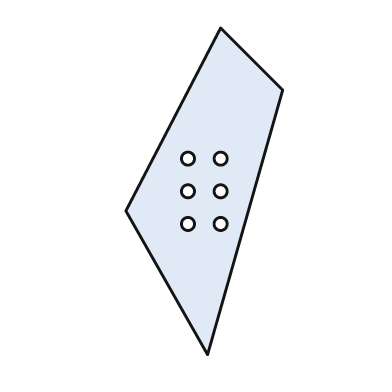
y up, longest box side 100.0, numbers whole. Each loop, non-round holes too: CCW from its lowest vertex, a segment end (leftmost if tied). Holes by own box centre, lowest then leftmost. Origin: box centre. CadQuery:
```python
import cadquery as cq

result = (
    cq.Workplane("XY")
    .moveTo(1.0, -50.0)
    .lineTo(24.0, 31.0)
    .lineTo(5.0, 50.0)
    .lineTo(-24.0, -6.0)
    .close()
    .moveTo(-5.0, -10.0)
    .circle(2.0)
    .moveTo(5.0, -10.0)
    .circle(2.0)
    .moveTo(-5.0, 0.0)
    .circle(2.0)
    .moveTo(5.0, 0.0)
    .circle(2.0)
    .moveTo(-5.0, 10.0)
    .circle(2.0)
    .moveTo(5.0, 10.0)
    .circle(2.0)
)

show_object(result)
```